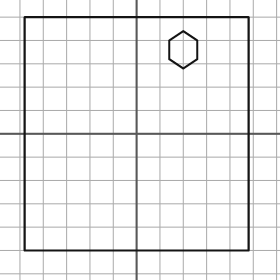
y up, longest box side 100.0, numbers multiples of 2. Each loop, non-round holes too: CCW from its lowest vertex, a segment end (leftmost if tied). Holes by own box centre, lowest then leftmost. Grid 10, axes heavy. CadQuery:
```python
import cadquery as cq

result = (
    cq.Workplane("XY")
    .moveTo(-48.0, -50.0)
    .lineTo(48.0, -50.0)
    .lineTo(48.0, 50.0)
    .lineTo(-48.0, 50.0)
    .close()
    .moveTo(20.0, 28.0)
    .lineTo(26.0, 32.0)
    .lineTo(26.0, 40.0)
    .lineTo(20.0, 44.0)
    .lineTo(14.0, 40.0)
    .lineTo(14.0, 32.0)
    .close()
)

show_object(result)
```